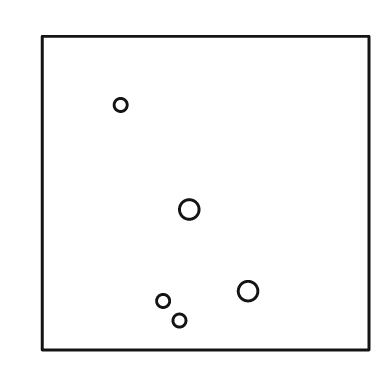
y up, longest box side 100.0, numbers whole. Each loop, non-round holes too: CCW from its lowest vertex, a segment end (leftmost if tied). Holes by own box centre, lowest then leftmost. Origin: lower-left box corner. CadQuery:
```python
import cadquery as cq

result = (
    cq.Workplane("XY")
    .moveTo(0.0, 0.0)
    .lineTo(100.0, 0.0)
    .lineTo(100.0, 96.0)
    .lineTo(0.0, 96.0)
    .close()
    .moveTo(42.0, 9.0)
    .circle(2.0)
    .moveTo(37.0, 15.0)
    .circle(2.0)
    .moveTo(63.0, 18.0)
    .circle(3.0)
    .moveTo(45.0, 43.0)
    .circle(3.0)
    .moveTo(24.0, 75.0)
    .circle(2.0)
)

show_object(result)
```